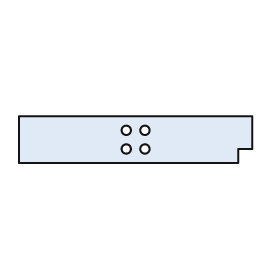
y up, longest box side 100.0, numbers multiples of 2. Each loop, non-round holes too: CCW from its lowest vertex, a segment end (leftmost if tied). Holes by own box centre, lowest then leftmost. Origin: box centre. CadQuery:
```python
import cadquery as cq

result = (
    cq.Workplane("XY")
    .moveTo(-50.0, -10.0)
    .lineTo(44.0, -10.0)
    .lineTo(44.0, -4.0)
    .lineTo(50.0, -4.0)
    .lineTo(50.0, 10.0)
    .lineTo(-50.0, 10.0)
    .close()
    .moveTo(-4.0, -4.0)
    .circle(2.0)
    .moveTo(4.0, -4.0)
    .circle(2.0)
    .moveTo(-4.0, 4.0)
    .circle(2.0)
    .moveTo(4.0, 4.0)
    .circle(2.0)
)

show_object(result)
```